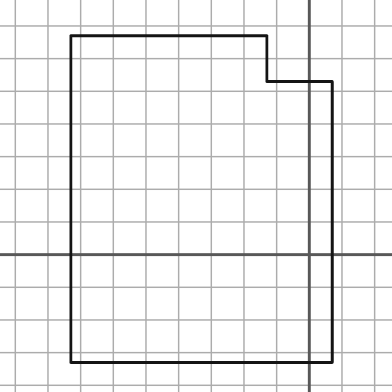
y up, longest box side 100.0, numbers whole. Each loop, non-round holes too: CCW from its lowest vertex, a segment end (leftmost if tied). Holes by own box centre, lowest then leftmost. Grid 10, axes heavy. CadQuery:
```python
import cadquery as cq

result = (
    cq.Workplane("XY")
    .moveTo(-73.0, -33.0)
    .lineTo(7.0, -33.0)
    .lineTo(7.0, 53.0)
    .lineTo(-13.0, 53.0)
    .lineTo(-13.0, 67.0)
    .lineTo(-73.0, 67.0)
    .close()
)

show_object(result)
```